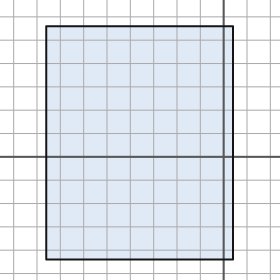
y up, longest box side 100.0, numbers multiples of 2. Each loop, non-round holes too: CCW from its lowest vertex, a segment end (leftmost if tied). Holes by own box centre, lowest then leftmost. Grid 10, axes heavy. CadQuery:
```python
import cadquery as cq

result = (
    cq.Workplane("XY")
    .moveTo(-76.0, -44.0)
    .lineTo(4.0, -44.0)
    .lineTo(4.0, 56.0)
    .lineTo(-76.0, 56.0)
    .close()
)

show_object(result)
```